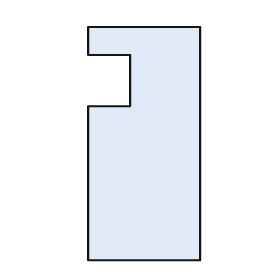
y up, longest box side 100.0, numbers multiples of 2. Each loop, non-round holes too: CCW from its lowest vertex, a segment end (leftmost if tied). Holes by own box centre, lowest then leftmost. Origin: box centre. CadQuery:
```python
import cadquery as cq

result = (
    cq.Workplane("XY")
    .moveTo(-24.0, -50.0)
    .lineTo(24.0, -50.0)
    .lineTo(24.0, 50.0)
    .lineTo(-24.0, 50.0)
    .lineTo(-24.0, 38.0)
    .lineTo(-6.0, 38.0)
    .lineTo(-6.0, 16.0)
    .lineTo(-24.0, 16.0)
    .close()
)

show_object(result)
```